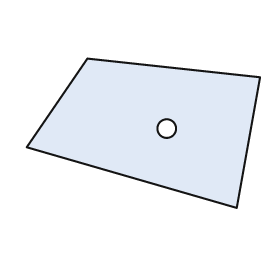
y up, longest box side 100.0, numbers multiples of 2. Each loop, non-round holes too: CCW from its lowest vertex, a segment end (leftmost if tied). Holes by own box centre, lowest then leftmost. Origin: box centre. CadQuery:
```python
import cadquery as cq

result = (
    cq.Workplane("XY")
    .moveTo(40.0, -32.0)
    .lineTo(50.0, 24.0)
    .lineTo(-24.0, 32.0)
    .lineTo(-50.0, -6.0)
    .close()
    .moveTo(10.0, 2.0)
    .circle(4.0)
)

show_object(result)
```